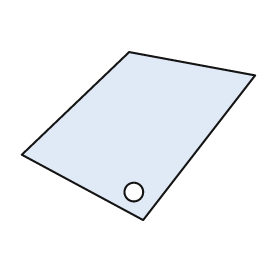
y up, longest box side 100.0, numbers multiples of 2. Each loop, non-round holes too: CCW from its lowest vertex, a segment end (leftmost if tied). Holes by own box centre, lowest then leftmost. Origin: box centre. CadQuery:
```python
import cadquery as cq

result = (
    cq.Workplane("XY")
    .moveTo(2.0, -36.0)
    .lineTo(50.0, 26.0)
    .lineTo(-4.0, 36.0)
    .lineTo(-50.0, -8.0)
    .close()
    .moveTo(-2.0, -24.0)
    .circle(4.0)
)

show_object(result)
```